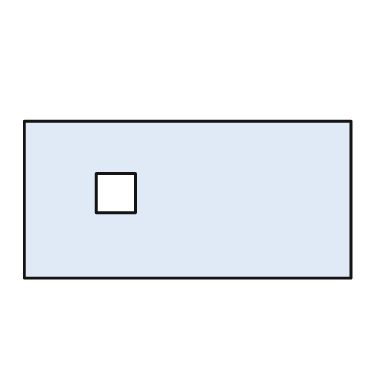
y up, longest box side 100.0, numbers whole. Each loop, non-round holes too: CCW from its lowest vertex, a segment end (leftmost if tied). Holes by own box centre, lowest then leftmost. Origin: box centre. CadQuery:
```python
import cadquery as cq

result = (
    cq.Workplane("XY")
    .moveTo(-50.0, -24.0)
    .lineTo(50.0, -24.0)
    .lineTo(50.0, 24.0)
    .lineTo(-50.0, 24.0)
    .close()
    .moveTo(-28.0, -4.0)
    .lineTo(-16.0, -4.0)
    .lineTo(-16.0, 8.0)
    .lineTo(-28.0, 8.0)
    .close()
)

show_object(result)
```